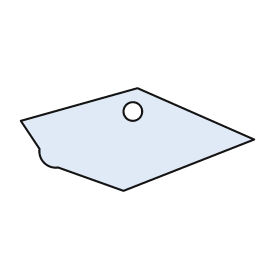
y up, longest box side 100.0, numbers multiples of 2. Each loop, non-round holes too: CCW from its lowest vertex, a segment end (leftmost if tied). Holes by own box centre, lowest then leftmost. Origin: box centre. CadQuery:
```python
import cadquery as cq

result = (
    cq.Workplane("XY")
    .moveTo(-6.0, -22.0)
    .lineTo(50.0, 0.0)
    .lineTo(0.0, 22.0)
    .lineTo(-50.0, 8.0)
    .lineTo(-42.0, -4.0)
    .threePointArc((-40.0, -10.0), (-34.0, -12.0))
    .close()
    .moveTo(-2.0, 12.0)
    .circle(4.0)
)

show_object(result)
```